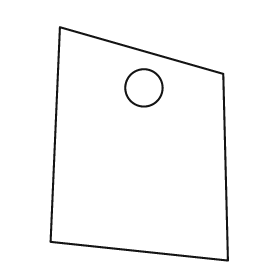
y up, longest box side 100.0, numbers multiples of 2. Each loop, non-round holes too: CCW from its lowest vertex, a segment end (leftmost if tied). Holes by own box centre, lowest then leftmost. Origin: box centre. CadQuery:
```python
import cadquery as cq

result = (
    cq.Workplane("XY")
    .moveTo(38.0, -50.0)
    .lineTo(36.0, 30.0)
    .lineTo(-34.0, 50.0)
    .lineTo(-38.0, -42.0)
    .close()
    .moveTo(2.0, 24.0)
    .circle(8.0)
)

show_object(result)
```